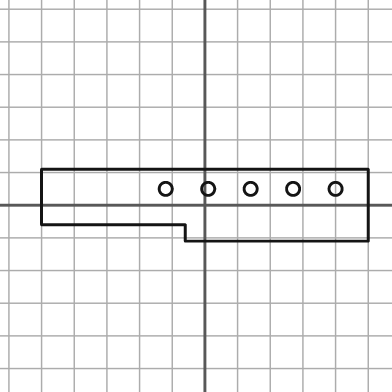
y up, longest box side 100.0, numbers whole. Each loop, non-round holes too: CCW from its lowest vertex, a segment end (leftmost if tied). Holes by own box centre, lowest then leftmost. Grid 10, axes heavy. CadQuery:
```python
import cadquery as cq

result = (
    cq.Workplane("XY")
    .moveTo(-6.0, -11.0)
    .lineTo(50.0, -11.0)
    .lineTo(50.0, 11.0)
    .lineTo(-50.0, 11.0)
    .lineTo(-50.0, -6.0)
    .lineTo(-6.0, -6.0)
    .close()
    .moveTo(-12.0, 5.0)
    .circle(2.0)
    .moveTo(1.0, 5.0)
    .circle(2.0)
    .moveTo(14.0, 5.0)
    .circle(2.0)
    .moveTo(27.0, 5.0)
    .circle(2.0)
    .moveTo(40.0, 5.0)
    .circle(2.0)
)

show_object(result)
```